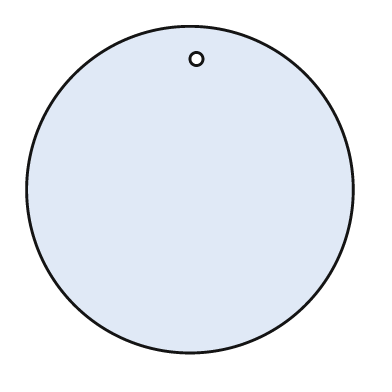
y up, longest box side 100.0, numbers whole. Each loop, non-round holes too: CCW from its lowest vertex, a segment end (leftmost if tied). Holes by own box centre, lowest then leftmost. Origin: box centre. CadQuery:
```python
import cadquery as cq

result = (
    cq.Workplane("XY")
    .moveTo(0.0, 0.0)
    .circle(50.0)
    .moveTo(2.0, 40.0)
    .circle(2.0)
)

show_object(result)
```